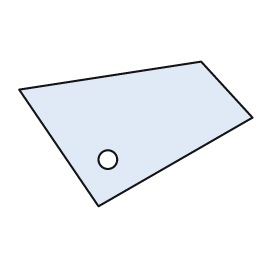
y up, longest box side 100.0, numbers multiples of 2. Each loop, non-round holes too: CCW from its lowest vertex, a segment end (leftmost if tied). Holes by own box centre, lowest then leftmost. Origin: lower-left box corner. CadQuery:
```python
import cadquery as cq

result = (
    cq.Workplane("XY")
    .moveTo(34.0, 0.0)
    .lineTo(100.0, 38.0)
    .lineTo(78.0, 62.0)
    .lineTo(0.0, 50.0)
    .close()
    .moveTo(38.0, 20.0)
    .circle(4.0)
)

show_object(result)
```